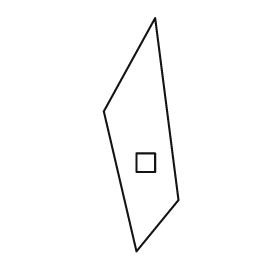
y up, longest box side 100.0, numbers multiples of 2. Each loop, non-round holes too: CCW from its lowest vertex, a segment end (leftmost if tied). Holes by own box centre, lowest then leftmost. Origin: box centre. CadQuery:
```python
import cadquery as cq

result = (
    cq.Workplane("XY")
    .moveTo(-2.0, -50.0)
    .lineTo(16.0, -28.0)
    .lineTo(6.0, 50.0)
    .lineTo(-16.0, 10.0)
    .close()
    .moveTo(-2.0, -16.0)
    .lineTo(6.0, -16.0)
    .lineTo(6.0, -8.0)
    .lineTo(-2.0, -8.0)
    .close()
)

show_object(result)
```